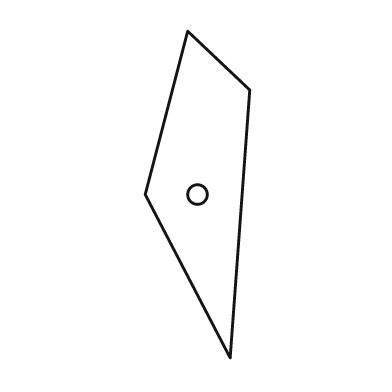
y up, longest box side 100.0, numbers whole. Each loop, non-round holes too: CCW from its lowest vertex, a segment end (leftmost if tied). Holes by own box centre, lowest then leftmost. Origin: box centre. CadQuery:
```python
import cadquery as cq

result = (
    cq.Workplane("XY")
    .moveTo(10.0, -50.0)
    .lineTo(16.0, 32.0)
    .lineTo(-3.0, 50.0)
    .lineTo(-16.0, 0.0)
    .close()
    .moveTo(0.0, 0.0)
    .circle(3.0)
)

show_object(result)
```